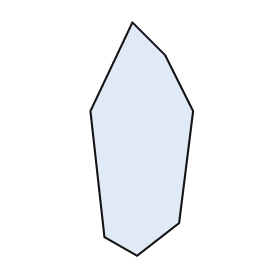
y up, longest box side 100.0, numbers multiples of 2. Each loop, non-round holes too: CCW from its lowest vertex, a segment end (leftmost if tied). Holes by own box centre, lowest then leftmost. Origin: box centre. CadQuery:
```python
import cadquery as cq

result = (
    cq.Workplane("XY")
    .moveTo(-2.0, -50.0)
    .lineTo(16.0, -36.0)
    .lineTo(22.0, 12.0)
    .lineTo(10.0, 36.0)
    .lineTo(-4.0, 50.0)
    .lineTo(-22.0, 12.0)
    .lineTo(-16.0, -42.0)
    .close()
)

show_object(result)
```